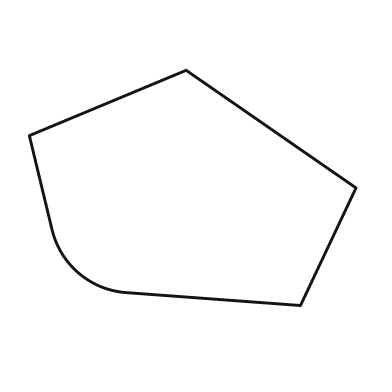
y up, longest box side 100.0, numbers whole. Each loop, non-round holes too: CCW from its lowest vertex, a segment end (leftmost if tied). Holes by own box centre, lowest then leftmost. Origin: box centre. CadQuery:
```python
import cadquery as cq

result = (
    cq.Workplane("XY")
    .moveTo(33.0, -36.0)
    .lineTo(50.0, 0.0)
    .lineTo(-2.0, 36.0)
    .lineTo(-50.0, 16.0)
    .lineTo(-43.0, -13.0)
    .threePointArc((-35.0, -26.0), (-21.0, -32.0))
    .close()
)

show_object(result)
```